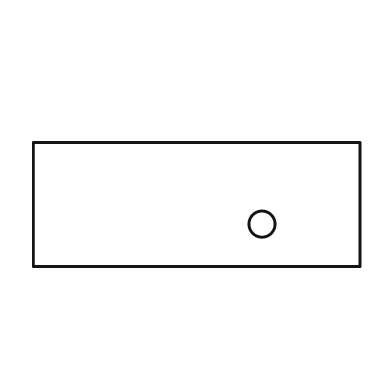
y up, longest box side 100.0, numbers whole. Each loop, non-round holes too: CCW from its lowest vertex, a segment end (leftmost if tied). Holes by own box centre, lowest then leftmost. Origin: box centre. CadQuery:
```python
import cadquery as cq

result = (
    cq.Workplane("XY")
    .moveTo(-50.0, -19.0)
    .lineTo(50.0, -19.0)
    .lineTo(50.0, 19.0)
    .lineTo(-50.0, 19.0)
    .close()
    .moveTo(20.0, -6.0)
    .circle(4.0)
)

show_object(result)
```